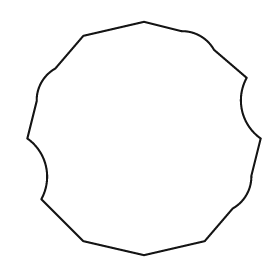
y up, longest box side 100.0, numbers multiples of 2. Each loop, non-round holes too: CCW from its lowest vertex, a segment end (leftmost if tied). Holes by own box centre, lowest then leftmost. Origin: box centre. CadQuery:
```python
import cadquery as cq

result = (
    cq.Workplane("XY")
    .moveTo(0.0, -50.0)
    .lineTo(26.0, -44.0)
    .lineTo(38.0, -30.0)
    .threePointArc((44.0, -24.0), (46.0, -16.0))
    .lineTo(50.0, 0.0)
    .threePointArc((42.0, 12.0), (44.0, 26.0))
    .lineTo(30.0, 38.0)
    .threePointArc((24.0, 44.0), (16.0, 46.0))
    .lineTo(0.0, 50.0)
    .lineTo(-26.0, 44.0)
    .lineTo(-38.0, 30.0)
    .threePointArc((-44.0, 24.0), (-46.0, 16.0))
    .lineTo(-50.0, 0.0)
    .threePointArc((-42.0, -12.0), (-44.0, -26.0))
    .lineTo(-26.0, -44.0)
    .close()
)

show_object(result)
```